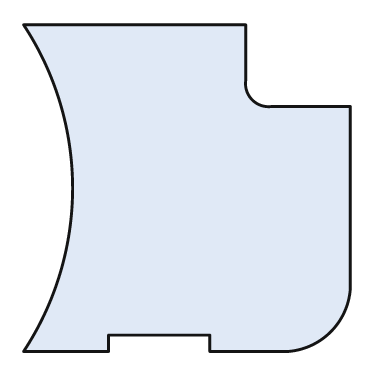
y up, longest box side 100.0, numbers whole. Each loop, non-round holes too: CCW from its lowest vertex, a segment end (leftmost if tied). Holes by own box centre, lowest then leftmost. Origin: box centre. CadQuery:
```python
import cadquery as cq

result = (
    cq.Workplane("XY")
    .moveTo(-50.0, -50.0)
    .lineTo(-24.0, -50.0)
    .lineTo(-24.0, -45.0)
    .lineTo(7.0, -45.0)
    .lineTo(7.0, -50.0)
    .lineTo(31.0, -50.0)
    .threePointArc((44.0, -44.0), (50.0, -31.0))
    .lineTo(50.0, 25.0)
    .lineTo(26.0, 25.0)
    .threePointArc((20.0, 27.0), (18.0, 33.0))
    .lineTo(18.0, 50.0)
    .lineTo(-50.0, 50.0)
    .threePointArc((-35.0, 0.0), (-50.0, -50.0))
    .close()
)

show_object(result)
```